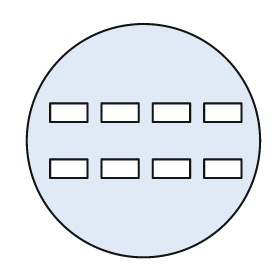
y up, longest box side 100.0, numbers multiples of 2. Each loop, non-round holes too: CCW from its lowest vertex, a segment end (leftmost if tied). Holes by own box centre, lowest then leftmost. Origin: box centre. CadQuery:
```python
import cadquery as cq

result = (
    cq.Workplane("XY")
    .moveTo(0.0, 0.0)
    .circle(50.0)
    .moveTo(-40.0, -16.0)
    .lineTo(-24.0, -16.0)
    .lineTo(-24.0, -8.0)
    .lineTo(-40.0, -8.0)
    .close()
    .moveTo(-18.0, -16.0)
    .lineTo(-2.0, -16.0)
    .lineTo(-2.0, -8.0)
    .lineTo(-18.0, -8.0)
    .close()
    .moveTo(4.0, -16.0)
    .lineTo(20.0, -16.0)
    .lineTo(20.0, -8.0)
    .lineTo(4.0, -8.0)
    .close()
    .moveTo(26.0, -16.0)
    .lineTo(42.0, -16.0)
    .lineTo(42.0, -8.0)
    .lineTo(26.0, -8.0)
    .close()
    .moveTo(-40.0, 8.0)
    .lineTo(-24.0, 8.0)
    .lineTo(-24.0, 16.0)
    .lineTo(-40.0, 16.0)
    .close()
    .moveTo(-18.0, 8.0)
    .lineTo(-2.0, 8.0)
    .lineTo(-2.0, 16.0)
    .lineTo(-18.0, 16.0)
    .close()
    .moveTo(4.0, 8.0)
    .lineTo(20.0, 8.0)
    .lineTo(20.0, 16.0)
    .lineTo(4.0, 16.0)
    .close()
    .moveTo(26.0, 8.0)
    .lineTo(42.0, 8.0)
    .lineTo(42.0, 16.0)
    .lineTo(26.0, 16.0)
    .close()
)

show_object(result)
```